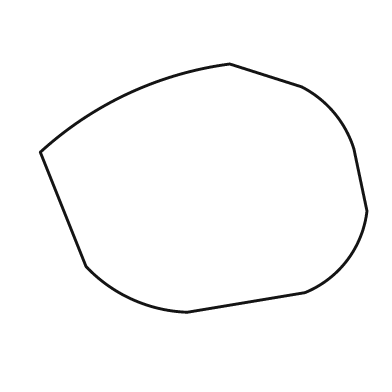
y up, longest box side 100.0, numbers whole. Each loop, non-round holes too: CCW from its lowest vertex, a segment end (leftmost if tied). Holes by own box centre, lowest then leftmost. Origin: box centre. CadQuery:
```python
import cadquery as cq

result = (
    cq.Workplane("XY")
    .moveTo(-5.0, -38.0)
    .lineTo(31.0, -32.0)
    .threePointArc((44.0, -22.0), (50.0, -7.0))
    .lineTo(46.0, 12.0)
    .threePointArc((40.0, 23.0), (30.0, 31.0))
    .lineTo(8.0, 38.0)
    .threePointArc((-23.0, 29.0), (-50.0, 11.0))
    .lineTo(-36.0, -24.0)
    .threePointArc((-22.0, -34.0), (-5.0, -38.0))
    .close()
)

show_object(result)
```